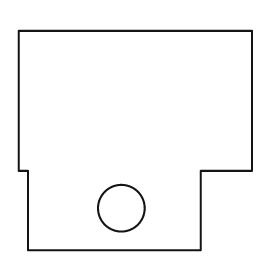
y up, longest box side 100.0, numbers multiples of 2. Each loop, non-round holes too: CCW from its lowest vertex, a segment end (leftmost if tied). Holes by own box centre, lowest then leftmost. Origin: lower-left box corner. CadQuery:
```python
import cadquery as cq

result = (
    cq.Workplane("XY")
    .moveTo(4.0, 0.0)
    .lineTo(78.0, 0.0)
    .lineTo(78.0, 34.0)
    .lineTo(100.0, 34.0)
    .lineTo(100.0, 94.0)
    .lineTo(0.0, 94.0)
    .lineTo(0.0, 34.0)
    .lineTo(4.0, 34.0)
    .close()
    .moveTo(44.0, 18.0)
    .circle(10.0)
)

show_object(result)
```